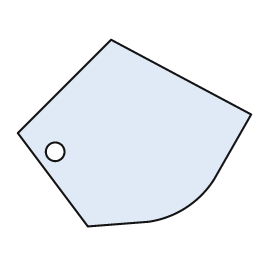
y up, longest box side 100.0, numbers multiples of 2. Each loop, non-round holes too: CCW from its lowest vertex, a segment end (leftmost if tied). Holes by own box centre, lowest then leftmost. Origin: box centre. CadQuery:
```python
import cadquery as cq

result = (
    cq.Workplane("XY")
    .moveTo(-20.0, -40.0)
    .lineTo(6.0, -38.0)
    .threePointArc((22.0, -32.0), (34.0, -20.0))
    .lineTo(50.0, 8.0)
    .lineTo(-10.0, 40.0)
    .lineTo(-50.0, 0.0)
    .close()
    .moveTo(-34.0, -8.0)
    .circle(4.0)
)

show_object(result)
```